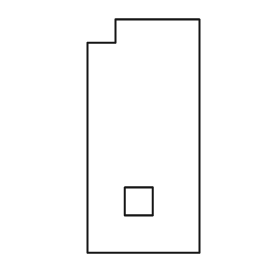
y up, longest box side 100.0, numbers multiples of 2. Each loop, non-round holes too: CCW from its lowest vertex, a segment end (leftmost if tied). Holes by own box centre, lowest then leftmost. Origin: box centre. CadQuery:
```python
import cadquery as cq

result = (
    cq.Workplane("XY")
    .moveTo(-24.0, -50.0)
    .lineTo(24.0, -50.0)
    .lineTo(24.0, 50.0)
    .lineTo(-12.0, 50.0)
    .lineTo(-12.0, 40.0)
    .lineTo(-24.0, 40.0)
    .close()
    .moveTo(-8.0, -34.0)
    .lineTo(4.0, -34.0)
    .lineTo(4.0, -22.0)
    .lineTo(-8.0, -22.0)
    .close()
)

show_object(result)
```